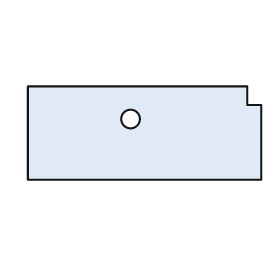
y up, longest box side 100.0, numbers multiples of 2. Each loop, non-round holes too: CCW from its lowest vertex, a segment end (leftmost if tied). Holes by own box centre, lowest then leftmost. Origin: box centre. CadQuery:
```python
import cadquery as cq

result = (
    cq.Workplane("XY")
    .moveTo(-50.0, -20.0)
    .lineTo(50.0, -20.0)
    .lineTo(50.0, 12.0)
    .lineTo(44.0, 12.0)
    .lineTo(44.0, 20.0)
    .lineTo(-50.0, 20.0)
    .close()
    .moveTo(-6.0, 6.0)
    .circle(4.0)
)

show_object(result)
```